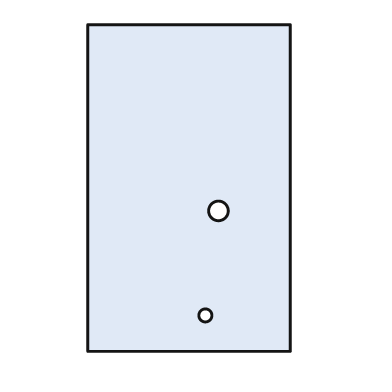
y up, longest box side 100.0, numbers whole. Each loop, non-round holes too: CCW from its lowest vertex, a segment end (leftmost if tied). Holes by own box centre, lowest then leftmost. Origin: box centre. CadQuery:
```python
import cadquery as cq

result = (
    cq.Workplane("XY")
    .moveTo(-31.0, -50.0)
    .lineTo(31.0, -50.0)
    .lineTo(31.0, 50.0)
    .lineTo(-31.0, 50.0)
    .close()
    .moveTo(5.0, -39.0)
    .circle(2.0)
    .moveTo(9.0, -7.0)
    .circle(3.0)
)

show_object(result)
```